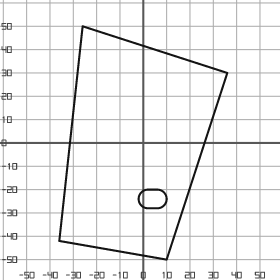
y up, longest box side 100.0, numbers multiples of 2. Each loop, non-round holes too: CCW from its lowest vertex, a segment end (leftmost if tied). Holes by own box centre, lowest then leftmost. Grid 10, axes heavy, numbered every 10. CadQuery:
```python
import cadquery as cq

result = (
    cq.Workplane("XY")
    .moveTo(10.0, -50.0)
    .lineTo(36.0, 30.0)
    .lineTo(-26.0, 50.0)
    .lineTo(-36.0, -42.0)
    .close()
    .moveTo(2.0, -28.0)
    .lineTo(6.0, -28.0)
    .threePointArc((10.0, -24.0), (6.0, -20.0))
    .lineTo(2.0, -20.0)
    .threePointArc((-2.0, -24.0), (2.0, -28.0))
    .close()
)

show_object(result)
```